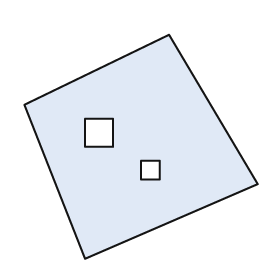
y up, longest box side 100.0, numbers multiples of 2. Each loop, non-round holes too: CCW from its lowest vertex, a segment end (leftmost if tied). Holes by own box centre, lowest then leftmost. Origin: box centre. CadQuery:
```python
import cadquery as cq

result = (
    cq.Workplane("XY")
    .moveTo(-24.0, -48.0)
    .lineTo(50.0, -16.0)
    .lineTo(12.0, 48.0)
    .lineTo(-50.0, 18.0)
    .close()
    .moveTo(0.0, -14.0)
    .lineTo(8.0, -14.0)
    .lineTo(8.0, -6.0)
    .lineTo(0.0, -6.0)
    .close()
    .moveTo(-24.0, 0.0)
    .lineTo(-12.0, 0.0)
    .lineTo(-12.0, 12.0)
    .lineTo(-24.0, 12.0)
    .close()
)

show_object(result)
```